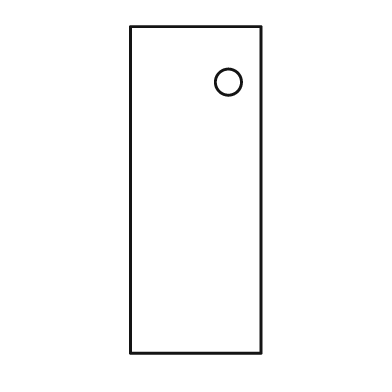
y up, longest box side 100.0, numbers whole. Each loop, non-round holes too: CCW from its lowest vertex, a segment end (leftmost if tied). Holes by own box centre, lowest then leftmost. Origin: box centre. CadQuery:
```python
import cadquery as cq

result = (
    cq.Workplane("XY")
    .moveTo(-20.0, -50.0)
    .lineTo(20.0, -50.0)
    .lineTo(20.0, 50.0)
    .lineTo(-20.0, 50.0)
    .close()
    .moveTo(10.0, 33.0)
    .circle(4.0)
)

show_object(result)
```